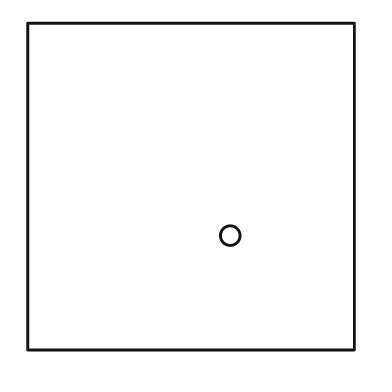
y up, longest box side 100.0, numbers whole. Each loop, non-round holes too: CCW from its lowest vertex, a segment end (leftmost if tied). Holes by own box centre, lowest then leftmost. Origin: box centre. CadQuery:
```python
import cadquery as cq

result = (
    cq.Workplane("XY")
    .moveTo(-50.0, -50.0)
    .lineTo(50.0, -50.0)
    .lineTo(50.0, 50.0)
    .lineTo(-50.0, 50.0)
    .close()
    .moveTo(12.0, -15.0)
    .circle(3.0)
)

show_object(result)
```